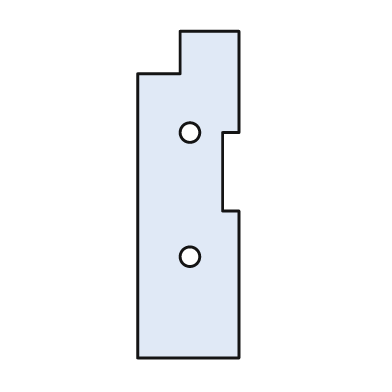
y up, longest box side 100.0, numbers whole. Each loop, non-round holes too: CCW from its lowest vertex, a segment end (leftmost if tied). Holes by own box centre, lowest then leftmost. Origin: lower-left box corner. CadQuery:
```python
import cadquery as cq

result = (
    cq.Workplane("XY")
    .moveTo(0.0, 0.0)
    .lineTo(31.0, 0.0)
    .lineTo(31.0, 45.0)
    .lineTo(26.0, 45.0)
    .lineTo(26.0, 69.0)
    .lineTo(31.0, 69.0)
    .lineTo(31.0, 100.0)
    .lineTo(13.0, 100.0)
    .lineTo(13.0, 87.0)
    .lineTo(0.0, 87.0)
    .close()
    .moveTo(16.0, 31.0)
    .circle(3.0)
    .moveTo(16.0, 69.0)
    .circle(3.0)
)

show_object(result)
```